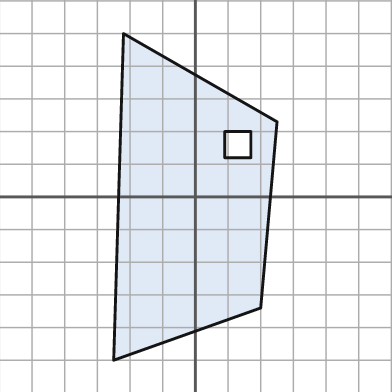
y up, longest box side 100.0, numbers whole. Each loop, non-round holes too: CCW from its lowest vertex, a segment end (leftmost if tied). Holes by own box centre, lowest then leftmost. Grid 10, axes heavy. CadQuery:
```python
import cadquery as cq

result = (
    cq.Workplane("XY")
    .moveTo(-25.0, -50.0)
    .lineTo(20.0, -34.0)
    .lineTo(25.0, 23.0)
    .lineTo(-22.0, 50.0)
    .close()
    .moveTo(9.0, 12.0)
    .lineTo(17.0, 12.0)
    .lineTo(17.0, 20.0)
    .lineTo(9.0, 20.0)
    .close()
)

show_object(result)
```